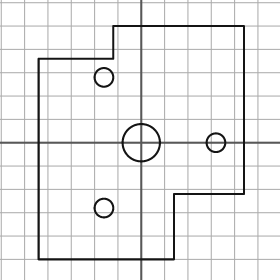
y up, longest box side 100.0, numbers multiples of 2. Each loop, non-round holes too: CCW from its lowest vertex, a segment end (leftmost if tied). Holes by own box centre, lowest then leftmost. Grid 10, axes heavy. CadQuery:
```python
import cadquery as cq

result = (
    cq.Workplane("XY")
    .moveTo(-44.0, -50.0)
    .lineTo(14.0, -50.0)
    .lineTo(14.0, -22.0)
    .lineTo(44.0, -22.0)
    .lineTo(44.0, 50.0)
    .lineTo(-12.0, 50.0)
    .lineTo(-12.0, 36.0)
    .lineTo(-44.0, 36.0)
    .close()
    .moveTo(-16.0, -28.0)
    .circle(4.0)
    .moveTo(0.0, 0.0)
    .circle(8.0)
    .moveTo(32.0, 0.0)
    .circle(4.0)
    .moveTo(-16.0, 28.0)
    .circle(4.0)
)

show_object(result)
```